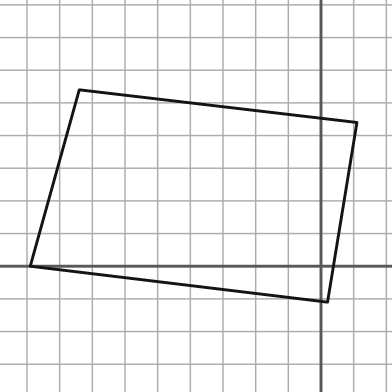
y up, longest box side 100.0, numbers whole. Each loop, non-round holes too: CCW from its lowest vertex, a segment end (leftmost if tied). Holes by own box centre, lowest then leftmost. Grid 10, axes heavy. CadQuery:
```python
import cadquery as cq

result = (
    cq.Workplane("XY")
    .moveTo(2.0, -11.0)
    .lineTo(11.0, 44.0)
    .lineTo(-74.0, 54.0)
    .lineTo(-89.0, 0.0)
    .close()
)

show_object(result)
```